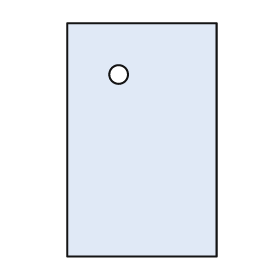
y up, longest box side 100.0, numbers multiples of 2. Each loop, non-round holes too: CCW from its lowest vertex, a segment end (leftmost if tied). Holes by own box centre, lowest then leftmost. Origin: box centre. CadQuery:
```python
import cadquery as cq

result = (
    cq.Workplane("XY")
    .moveTo(-32.0, -50.0)
    .lineTo(32.0, -50.0)
    .lineTo(32.0, 50.0)
    .lineTo(-32.0, 50.0)
    .close()
    .moveTo(-10.0, 28.0)
    .circle(4.0)
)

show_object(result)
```